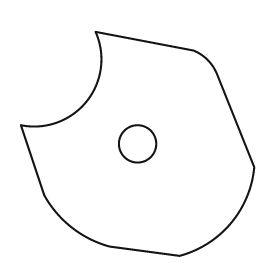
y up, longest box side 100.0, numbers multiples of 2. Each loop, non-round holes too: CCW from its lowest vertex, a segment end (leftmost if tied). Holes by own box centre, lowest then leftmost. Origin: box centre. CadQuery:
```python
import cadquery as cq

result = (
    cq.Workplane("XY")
    .moveTo(18.0, -48.0)
    .threePointArc((40.0, -34.0), (50.0, -10.0))
    .lineTo(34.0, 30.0)
    .threePointArc((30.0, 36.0), (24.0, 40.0))
    .lineTo(-18.0, 48.0)
    .threePointArc((-22.0, 18.0), (-50.0, 8.0))
    .lineTo(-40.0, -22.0)
    .threePointArc((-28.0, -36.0), (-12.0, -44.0))
    .close()
    .moveTo(0.0, 0.0)
    .circle(8.0)
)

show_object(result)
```